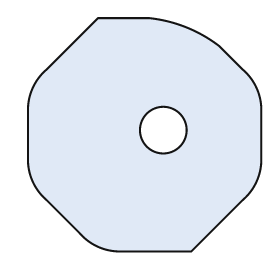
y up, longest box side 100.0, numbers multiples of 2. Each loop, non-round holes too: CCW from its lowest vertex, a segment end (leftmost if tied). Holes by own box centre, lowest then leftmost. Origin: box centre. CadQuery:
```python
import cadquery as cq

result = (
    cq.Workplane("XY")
    .moveTo(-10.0, -50.0)
    .lineTo(20.0, -50.0)
    .lineTo(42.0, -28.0)
    .threePointArc((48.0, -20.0), (50.0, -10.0))
    .lineTo(50.0, 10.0)
    .threePointArc((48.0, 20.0), (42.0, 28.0))
    .lineTo(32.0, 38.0)
    .threePointArc((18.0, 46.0), (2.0, 50.0))
    .lineTo(-20.0, 50.0)
    .lineTo(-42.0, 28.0)
    .threePointArc((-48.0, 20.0), (-50.0, 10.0))
    .lineTo(-50.0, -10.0)
    .threePointArc((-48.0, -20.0), (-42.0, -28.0))
    .lineTo(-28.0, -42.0)
    .threePointArc((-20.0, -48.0), (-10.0, -50.0))
    .close()
    .moveTo(8.0, 2.0)
    .circle(10.0)
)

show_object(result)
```